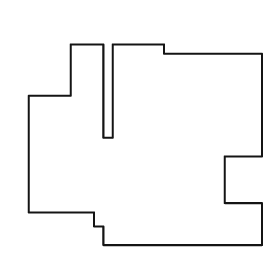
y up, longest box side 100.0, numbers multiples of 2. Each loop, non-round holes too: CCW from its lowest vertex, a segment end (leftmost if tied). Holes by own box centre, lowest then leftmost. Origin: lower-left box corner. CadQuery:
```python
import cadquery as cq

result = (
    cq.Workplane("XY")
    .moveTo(32.0, 0.0)
    .lineTo(100.0, 0.0)
    .lineTo(100.0, 18.0)
    .lineTo(84.0, 18.0)
    .lineTo(84.0, 38.0)
    .lineTo(100.0, 38.0)
    .lineTo(100.0, 82.0)
    .lineTo(58.0, 82.0)
    .lineTo(58.0, 86.0)
    .lineTo(36.0, 86.0)
    .lineTo(36.0, 46.0)
    .lineTo(32.0, 46.0)
    .lineTo(32.0, 86.0)
    .lineTo(18.0, 86.0)
    .lineTo(18.0, 64.0)
    .lineTo(0.0, 64.0)
    .lineTo(0.0, 14.0)
    .lineTo(28.0, 14.0)
    .lineTo(28.0, 8.0)
    .lineTo(32.0, 8.0)
    .close()
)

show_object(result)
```